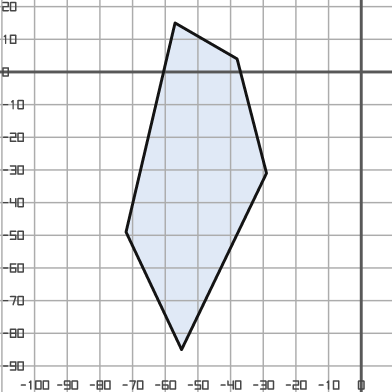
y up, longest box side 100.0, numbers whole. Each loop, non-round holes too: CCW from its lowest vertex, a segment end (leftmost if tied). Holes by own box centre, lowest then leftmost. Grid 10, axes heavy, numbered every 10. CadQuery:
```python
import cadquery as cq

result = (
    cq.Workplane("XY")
    .moveTo(-55.0, -85.0)
    .lineTo(-29.0, -31.0)
    .lineTo(-38.0, 4.0)
    .lineTo(-57.0, 15.0)
    .lineTo(-72.0, -49.0)
    .close()
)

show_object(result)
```